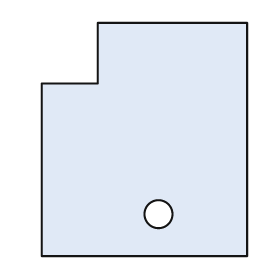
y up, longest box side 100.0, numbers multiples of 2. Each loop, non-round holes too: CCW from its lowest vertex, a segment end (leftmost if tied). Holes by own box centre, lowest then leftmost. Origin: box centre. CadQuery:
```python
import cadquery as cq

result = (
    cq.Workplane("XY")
    .moveTo(-44.0, -50.0)
    .lineTo(44.0, -50.0)
    .lineTo(44.0, 50.0)
    .lineTo(-20.0, 50.0)
    .lineTo(-20.0, 24.0)
    .lineTo(-44.0, 24.0)
    .close()
    .moveTo(6.0, -32.0)
    .circle(6.0)
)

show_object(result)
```